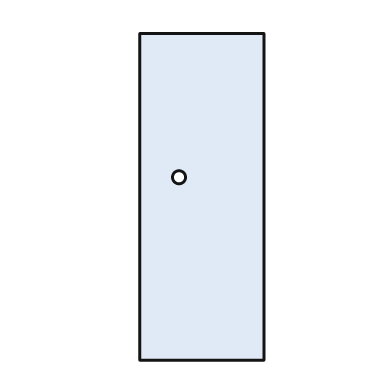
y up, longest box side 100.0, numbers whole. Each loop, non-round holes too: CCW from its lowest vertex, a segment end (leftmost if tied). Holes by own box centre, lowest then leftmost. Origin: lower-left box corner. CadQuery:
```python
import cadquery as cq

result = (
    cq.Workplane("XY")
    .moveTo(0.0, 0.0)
    .lineTo(38.0, 0.0)
    .lineTo(38.0, 100.0)
    .lineTo(0.0, 100.0)
    .close()
    .moveTo(12.0, 56.0)
    .circle(2.0)
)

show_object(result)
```